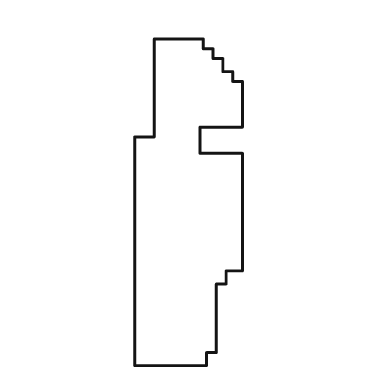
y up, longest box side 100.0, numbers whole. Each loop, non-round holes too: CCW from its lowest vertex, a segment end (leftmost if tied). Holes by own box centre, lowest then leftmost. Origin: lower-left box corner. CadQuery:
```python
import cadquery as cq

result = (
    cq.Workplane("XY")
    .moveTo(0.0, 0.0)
    .lineTo(22.0, 0.0)
    .lineTo(22.0, 4.0)
    .lineTo(25.0, 4.0)
    .lineTo(25.0, 25.0)
    .lineTo(28.0, 25.0)
    .lineTo(28.0, 29.0)
    .lineTo(33.0, 29.0)
    .lineTo(33.0, 65.0)
    .lineTo(20.0, 65.0)
    .lineTo(20.0, 73.0)
    .lineTo(33.0, 73.0)
    .lineTo(33.0, 87.0)
    .lineTo(30.0, 87.0)
    .lineTo(30.0, 90.0)
    .lineTo(27.0, 90.0)
    .lineTo(27.0, 94.0)
    .lineTo(24.0, 94.0)
    .lineTo(24.0, 97.0)
    .lineTo(21.0, 97.0)
    .lineTo(21.0, 100.0)
    .lineTo(6.0, 100.0)
    .lineTo(6.0, 70.0)
    .lineTo(0.0, 70.0)
    .close()
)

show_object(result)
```